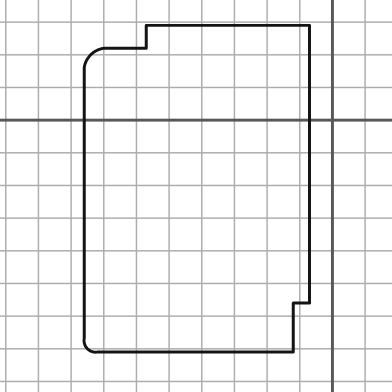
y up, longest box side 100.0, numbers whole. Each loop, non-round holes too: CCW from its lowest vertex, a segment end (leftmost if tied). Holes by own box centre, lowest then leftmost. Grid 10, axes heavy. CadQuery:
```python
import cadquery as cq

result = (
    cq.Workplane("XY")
    .moveTo(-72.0, -71.0)
    .lineTo(-12.0, -71.0)
    .lineTo(-12.0, -56.0)
    .lineTo(-7.0, -56.0)
    .lineTo(-7.0, 29.0)
    .lineTo(-57.0, 29.0)
    .lineTo(-57.0, 22.0)
    .lineTo(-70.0, 22.0)
    .threePointArc((-74.0, 20.0), (-76.0, 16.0))
    .lineTo(-76.0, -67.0)
    .threePointArc((-75.0, -70.0), (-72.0, -71.0))
    .close()
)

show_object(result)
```